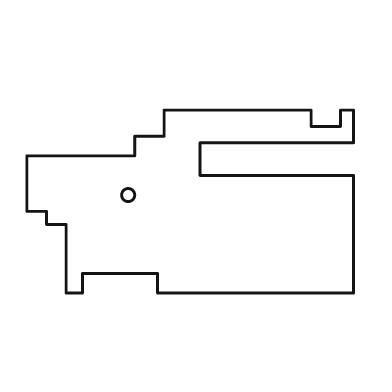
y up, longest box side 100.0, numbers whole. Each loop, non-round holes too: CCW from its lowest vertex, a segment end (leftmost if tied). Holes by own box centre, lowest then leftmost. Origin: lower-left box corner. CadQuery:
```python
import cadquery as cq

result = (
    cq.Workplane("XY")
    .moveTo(12.0, 0.0)
    .lineTo(17.0, 0.0)
    .lineTo(17.0, 6.0)
    .lineTo(40.0, 6.0)
    .lineTo(40.0, 0.0)
    .lineTo(100.0, 0.0)
    .lineTo(100.0, 36.0)
    .lineTo(53.0, 36.0)
    .lineTo(53.0, 46.0)
    .lineTo(100.0, 46.0)
    .lineTo(100.0, 56.0)
    .lineTo(96.0, 56.0)
    .lineTo(96.0, 51.0)
    .lineTo(87.0, 51.0)
    .lineTo(87.0, 56.0)
    .lineTo(42.0, 56.0)
    .lineTo(42.0, 48.0)
    .lineTo(33.0, 48.0)
    .lineTo(33.0, 42.0)
    .lineTo(0.0, 42.0)
    .lineTo(0.0, 25.0)
    .lineTo(6.0, 25.0)
    .lineTo(6.0, 21.0)
    .lineTo(12.0, 21.0)
    .close()
    .moveTo(31.0, 30.0)
    .circle(2.0)
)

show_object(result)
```